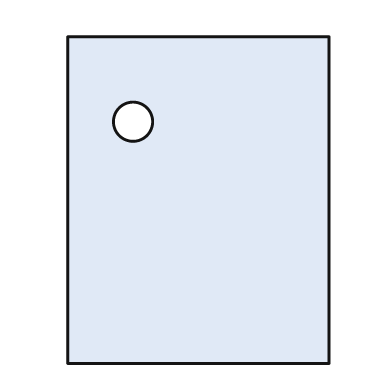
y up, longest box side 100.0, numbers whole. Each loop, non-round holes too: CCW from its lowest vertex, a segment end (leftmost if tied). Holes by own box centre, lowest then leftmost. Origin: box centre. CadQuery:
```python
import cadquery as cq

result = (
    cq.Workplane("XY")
    .moveTo(-40.0, -50.0)
    .lineTo(40.0, -50.0)
    .lineTo(40.0, 50.0)
    .lineTo(-40.0, 50.0)
    .close()
    .moveTo(-20.0, 24.0)
    .circle(6.0)
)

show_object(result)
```